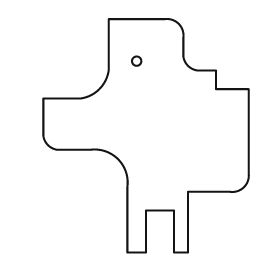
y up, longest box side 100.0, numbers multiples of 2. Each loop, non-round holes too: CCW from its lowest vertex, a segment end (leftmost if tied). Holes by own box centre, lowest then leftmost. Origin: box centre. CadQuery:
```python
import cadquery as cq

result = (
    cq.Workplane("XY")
    .moveTo(-8.0, -50.0)
    .lineTo(0.0, -50.0)
    .lineTo(0.0, -32.0)
    .lineTo(12.0, -32.0)
    .lineTo(12.0, -50.0)
    .lineTo(18.0, -50.0)
    .lineTo(18.0, -24.0)
    .lineTo(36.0, -24.0)
    .threePointArc((42.0, -22.0), (44.0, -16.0))
    .lineTo(44.0, 20.0)
    .lineTo(30.0, 20.0)
    .lineTo(30.0, 28.0)
    .lineTo(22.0, 28.0)
    .threePointArc((18.0, 30.0), (16.0, 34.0))
    .lineTo(16.0, 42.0)
    .threePointArc((14.0, 48.0), (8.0, 50.0))
    .lineTo(-16.0, 50.0)
    .lineTo(-16.0, 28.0)
    .threePointArc((-20.0, 20.0), (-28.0, 16.0))
    .lineTo(-44.0, 16.0)
    .lineTo(-44.0, 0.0)
    .threePointArc((-42.0, -4.0), (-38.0, -6.0))
    .lineTo(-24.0, -6.0)
    .threePointArc((-12.0, -10.0), (-8.0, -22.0))
    .close()
    .moveTo(-4.0, 32.0)
    .circle(2.0)
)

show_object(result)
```